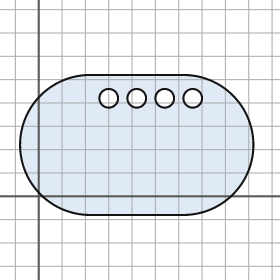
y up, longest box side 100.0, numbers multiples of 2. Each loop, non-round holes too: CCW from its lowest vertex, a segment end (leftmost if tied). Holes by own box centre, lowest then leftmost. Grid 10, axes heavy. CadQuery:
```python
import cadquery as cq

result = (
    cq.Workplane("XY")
    .moveTo(22.0, -8.0)
    .lineTo(62.0, -8.0)
    .threePointArc((92.0, 22.0), (62.0, 52.0))
    .lineTo(22.0, 52.0)
    .threePointArc((-8.0, 22.0), (22.0, -8.0))
    .close()
    .moveTo(30.0, 42.0)
    .circle(4.0)
    .moveTo(42.0, 42.0)
    .circle(4.0)
    .moveTo(54.0, 42.0)
    .circle(4.0)
    .moveTo(66.0, 42.0)
    .circle(4.0)
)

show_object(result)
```